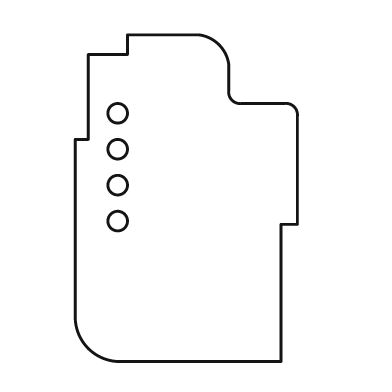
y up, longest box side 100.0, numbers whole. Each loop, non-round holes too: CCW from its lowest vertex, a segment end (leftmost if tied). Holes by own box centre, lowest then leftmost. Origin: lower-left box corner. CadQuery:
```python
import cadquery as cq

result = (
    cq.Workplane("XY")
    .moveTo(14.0, 0.0)
    .lineTo(63.0, 0.0)
    .lineTo(63.0, 42.0)
    .lineTo(68.0, 42.0)
    .lineTo(68.0, 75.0)
    .threePointArc((67.0, 78.0), (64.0, 79.0))
    .lineTo(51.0, 79.0)
    .threePointArc((48.0, 80.0), (47.0, 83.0))
    .lineTo(47.0, 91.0)
    .threePointArc((44.0, 97.0), (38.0, 100.0))
    .lineTo(16.0, 100.0)
    .lineTo(16.0, 94.0)
    .lineTo(4.0, 94.0)
    .lineTo(4.0, 68.0)
    .lineTo(0.0, 68.0)
    .lineTo(0.0, 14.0)
    .threePointArc((4.0, 4.0), (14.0, 0.0))
    .close()
    .moveTo(13.0, 43.0)
    .circle(3.0)
    .moveTo(13.0, 54.0)
    .circle(3.0)
    .moveTo(13.0, 65.0)
    .circle(3.0)
    .moveTo(13.0, 76.0)
    .circle(3.0)
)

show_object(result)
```